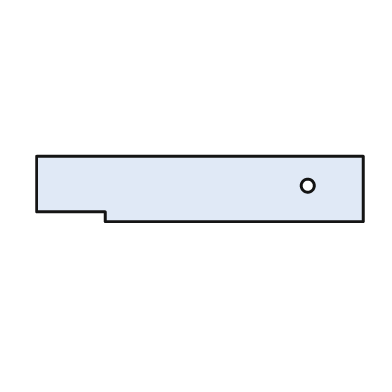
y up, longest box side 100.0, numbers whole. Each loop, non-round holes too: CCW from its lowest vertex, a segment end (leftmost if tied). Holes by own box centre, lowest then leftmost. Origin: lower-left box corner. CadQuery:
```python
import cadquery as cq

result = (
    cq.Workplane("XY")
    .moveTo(21.0, 0.0)
    .lineTo(100.0, 0.0)
    .lineTo(100.0, 20.0)
    .lineTo(0.0, 20.0)
    .lineTo(0.0, 3.0)
    .lineTo(21.0, 3.0)
    .close()
    .moveTo(83.0, 11.0)
    .circle(2.0)
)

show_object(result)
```